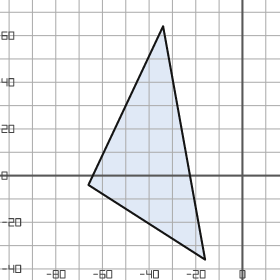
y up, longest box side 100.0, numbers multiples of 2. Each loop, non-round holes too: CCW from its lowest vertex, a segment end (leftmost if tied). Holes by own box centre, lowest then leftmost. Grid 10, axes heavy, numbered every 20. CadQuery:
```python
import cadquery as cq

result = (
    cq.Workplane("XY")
    .moveTo(-16.0, -36.0)
    .lineTo(-34.0, 64.0)
    .lineTo(-66.0, -4.0)
    .close()
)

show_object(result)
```